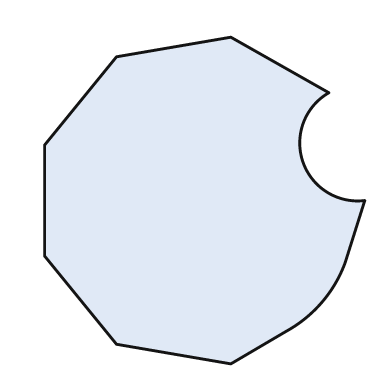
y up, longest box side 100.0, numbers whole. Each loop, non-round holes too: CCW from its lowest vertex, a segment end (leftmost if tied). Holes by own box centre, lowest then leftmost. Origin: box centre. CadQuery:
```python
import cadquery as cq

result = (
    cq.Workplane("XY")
    .moveTo(8.0, -50.0)
    .lineTo(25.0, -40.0)
    .threePointArc((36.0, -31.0), (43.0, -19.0))
    .lineTo(49.0, 0.0)
    .threePointArc((30.0, 12.0), (38.0, 33.0))
    .lineTo(8.0, 50.0)
    .lineTo(-27.0, 44.0)
    .lineTo(-49.0, 17.0)
    .lineTo(-49.0, -17.0)
    .lineTo(-27.0, -44.0)
    .close()
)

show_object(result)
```